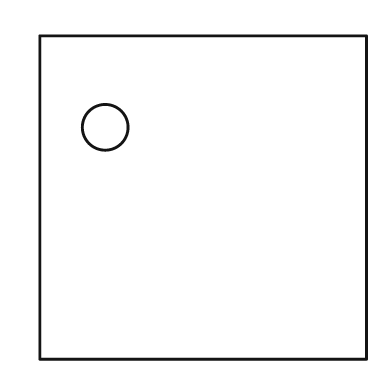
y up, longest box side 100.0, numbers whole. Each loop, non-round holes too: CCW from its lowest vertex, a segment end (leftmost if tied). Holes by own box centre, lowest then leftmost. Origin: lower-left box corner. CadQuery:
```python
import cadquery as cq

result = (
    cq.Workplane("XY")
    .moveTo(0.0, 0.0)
    .lineTo(100.0, 0.0)
    .lineTo(100.0, 99.0)
    .lineTo(0.0, 99.0)
    .close()
    .moveTo(20.0, 71.0)
    .circle(7.0)
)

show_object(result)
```